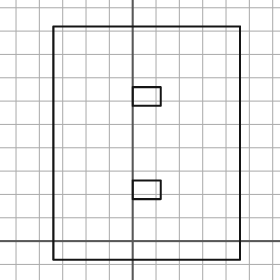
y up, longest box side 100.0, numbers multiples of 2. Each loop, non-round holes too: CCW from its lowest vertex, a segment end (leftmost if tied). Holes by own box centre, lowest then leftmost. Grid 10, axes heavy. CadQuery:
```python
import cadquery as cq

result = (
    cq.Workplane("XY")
    .moveTo(-34.0, -8.0)
    .lineTo(46.0, -8.0)
    .lineTo(46.0, 92.0)
    .lineTo(-34.0, 92.0)
    .close()
    .moveTo(0.0, 18.0)
    .lineTo(12.0, 18.0)
    .lineTo(12.0, 26.0)
    .lineTo(0.0, 26.0)
    .close()
    .moveTo(0.0, 58.0)
    .lineTo(12.0, 58.0)
    .lineTo(12.0, 66.0)
    .lineTo(0.0, 66.0)
    .close()
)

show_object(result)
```